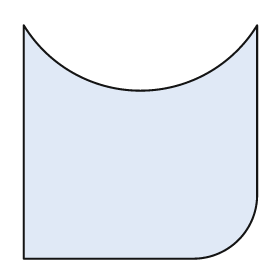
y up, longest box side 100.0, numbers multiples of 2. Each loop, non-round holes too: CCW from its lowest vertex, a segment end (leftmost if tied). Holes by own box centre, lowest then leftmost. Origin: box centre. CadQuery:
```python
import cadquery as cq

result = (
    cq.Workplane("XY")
    .moveTo(-50.0, -50.0)
    .lineTo(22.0, -50.0)
    .threePointArc((42.0, -42.0), (50.0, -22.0))
    .lineTo(50.0, 50.0)
    .threePointArc((0.0, 22.0), (-50.0, 50.0))
    .close()
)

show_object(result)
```